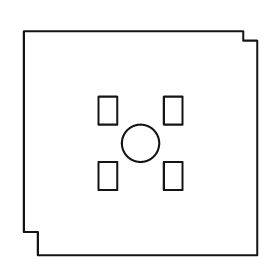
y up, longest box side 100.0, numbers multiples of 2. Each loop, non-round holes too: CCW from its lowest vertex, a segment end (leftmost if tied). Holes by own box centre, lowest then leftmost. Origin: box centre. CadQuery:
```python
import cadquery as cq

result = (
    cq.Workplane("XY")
    .moveTo(-44.0, -48.0)
    .lineTo(50.0, -48.0)
    .lineTo(50.0, 44.0)
    .lineTo(44.0, 44.0)
    .lineTo(44.0, 48.0)
    .lineTo(-50.0, 48.0)
    .lineTo(-50.0, -38.0)
    .lineTo(-44.0, -38.0)
    .close()
    .moveTo(-18.0, -20.0)
    .lineTo(-10.0, -20.0)
    .lineTo(-10.0, -8.0)
    .lineTo(-18.0, -8.0)
    .close()
    .moveTo(10.0, -20.0)
    .lineTo(18.0, -20.0)
    .lineTo(18.0, -8.0)
    .lineTo(10.0, -8.0)
    .close()
    .moveTo(0.0, 0.0)
    .circle(8.0)
    .moveTo(-18.0, 8.0)
    .lineTo(-10.0, 8.0)
    .lineTo(-10.0, 20.0)
    .lineTo(-18.0, 20.0)
    .close()
    .moveTo(10.0, 8.0)
    .lineTo(18.0, 8.0)
    .lineTo(18.0, 20.0)
    .lineTo(10.0, 20.0)
    .close()
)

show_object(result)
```